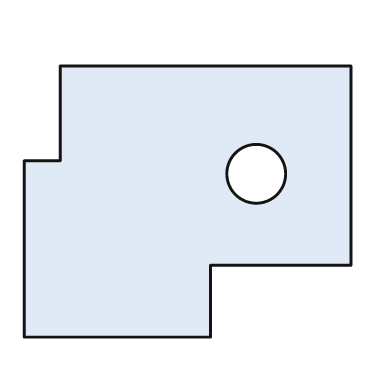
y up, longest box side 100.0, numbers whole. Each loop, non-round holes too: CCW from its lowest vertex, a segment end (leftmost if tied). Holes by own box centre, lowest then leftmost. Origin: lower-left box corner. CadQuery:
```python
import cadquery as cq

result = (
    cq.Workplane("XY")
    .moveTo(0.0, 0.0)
    .lineTo(57.0, 0.0)
    .lineTo(57.0, 22.0)
    .lineTo(100.0, 22.0)
    .lineTo(100.0, 83.0)
    .lineTo(11.0, 83.0)
    .lineTo(11.0, 54.0)
    .lineTo(0.0, 54.0)
    .close()
    .moveTo(71.0, 50.0)
    .circle(9.0)
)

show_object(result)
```